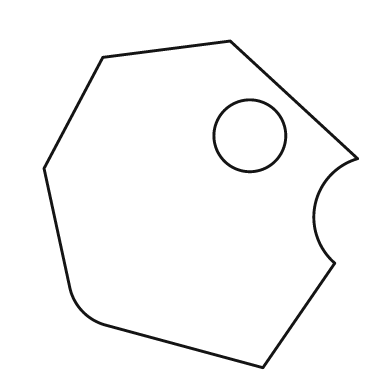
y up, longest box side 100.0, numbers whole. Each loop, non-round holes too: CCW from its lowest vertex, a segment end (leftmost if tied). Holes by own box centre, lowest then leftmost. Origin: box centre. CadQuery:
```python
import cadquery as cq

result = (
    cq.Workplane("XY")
    .moveTo(19.0, -50.0)
    .lineTo(41.0, -18.0)
    .threePointArc((35.0, 0.0), (48.0, 14.0))
    .lineTo(9.0, 50.0)
    .lineTo(-30.0, 45.0)
    .lineTo(-48.0, 11.0)
    .lineTo(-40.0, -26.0)
    .threePointArc((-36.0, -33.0), (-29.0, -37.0))
    .close()
    .moveTo(15.0, 21.0)
    .circle(11.0)
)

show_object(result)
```